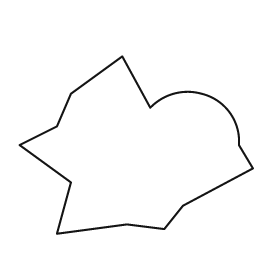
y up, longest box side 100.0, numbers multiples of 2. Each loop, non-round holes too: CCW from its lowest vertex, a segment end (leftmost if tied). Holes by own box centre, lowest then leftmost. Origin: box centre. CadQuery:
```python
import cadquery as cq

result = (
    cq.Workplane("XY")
    .moveTo(-34.0, -38.0)
    .lineTo(-4.0, -34.0)
    .lineTo(12.0, -36.0)
    .lineTo(20.0, -26.0)
    .lineTo(50.0, -10.0)
    .lineTo(44.0, 0.0)
    .threePointArc((40.0, 14.0), (28.0, 22.0))
    .threePointArc((16.0, 22.0), (6.0, 16.0))
    .lineTo(-6.0, 38.0)
    .lineTo(-28.0, 22.0)
    .lineTo(-34.0, 8.0)
    .lineTo(-50.0, 0.0)
    .lineTo(-28.0, -16.0)
    .close()
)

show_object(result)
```